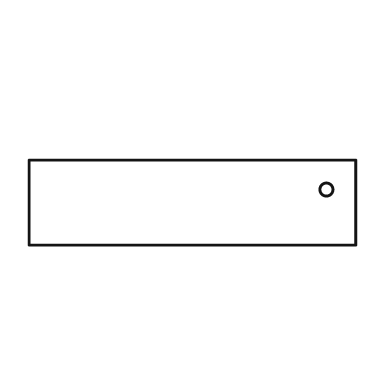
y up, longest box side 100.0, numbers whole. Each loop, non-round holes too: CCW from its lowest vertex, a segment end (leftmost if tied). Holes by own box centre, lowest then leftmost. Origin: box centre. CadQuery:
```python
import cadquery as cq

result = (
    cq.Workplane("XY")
    .moveTo(-50.0, -13.0)
    .lineTo(50.0, -13.0)
    .lineTo(50.0, 13.0)
    .lineTo(-50.0, 13.0)
    .close()
    .moveTo(41.0, 4.0)
    .circle(2.0)
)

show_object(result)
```